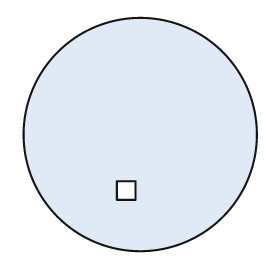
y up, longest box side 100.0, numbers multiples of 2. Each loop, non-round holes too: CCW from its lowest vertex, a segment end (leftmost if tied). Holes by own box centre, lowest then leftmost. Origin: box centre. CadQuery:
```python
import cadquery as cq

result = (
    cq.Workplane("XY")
    .moveTo(0.0, 0.0)
    .circle(50.0)
    .moveTo(-10.0, -28.0)
    .lineTo(-2.0, -28.0)
    .lineTo(-2.0, -20.0)
    .lineTo(-10.0, -20.0)
    .close()
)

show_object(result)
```